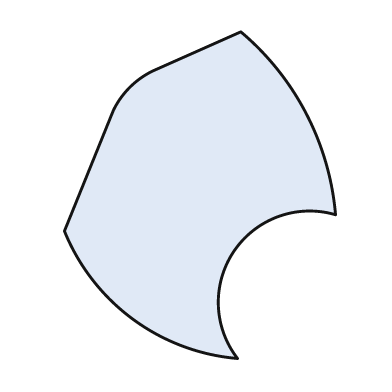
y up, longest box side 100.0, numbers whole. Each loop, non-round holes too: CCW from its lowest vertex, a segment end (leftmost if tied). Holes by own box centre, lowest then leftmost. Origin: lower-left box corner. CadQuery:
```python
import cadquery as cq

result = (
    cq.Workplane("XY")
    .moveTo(53.0, 0.0)
    .threePointArc((52.0, 33.0), (83.0, 44.0))
    .threePointArc((74.0, 75.0), (54.0, 100.0))
    .lineTo(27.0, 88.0)
    .threePointArc((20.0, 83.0), (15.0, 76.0))
    .lineTo(0.0, 39.0)
    .threePointArc((21.0, 12.0), (53.0, 0.0))
    .close()
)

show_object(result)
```